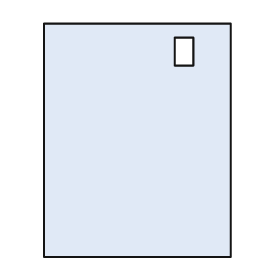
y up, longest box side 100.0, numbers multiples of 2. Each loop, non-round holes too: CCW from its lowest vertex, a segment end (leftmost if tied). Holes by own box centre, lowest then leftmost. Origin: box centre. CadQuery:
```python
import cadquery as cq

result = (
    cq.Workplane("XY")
    .moveTo(-40.0, -50.0)
    .lineTo(40.0, -50.0)
    .lineTo(40.0, 50.0)
    .lineTo(-40.0, 50.0)
    .close()
    .moveTo(16.0, 32.0)
    .lineTo(24.0, 32.0)
    .lineTo(24.0, 44.0)
    .lineTo(16.0, 44.0)
    .close()
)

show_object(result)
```